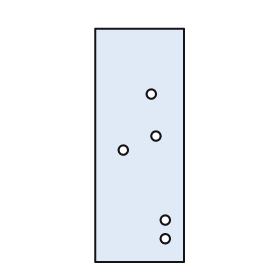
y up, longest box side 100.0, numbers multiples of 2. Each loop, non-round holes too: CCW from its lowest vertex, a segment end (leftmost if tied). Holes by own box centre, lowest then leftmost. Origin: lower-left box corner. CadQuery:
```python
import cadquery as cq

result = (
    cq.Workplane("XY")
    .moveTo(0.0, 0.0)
    .lineTo(38.0, 0.0)
    .lineTo(38.0, 100.0)
    .lineTo(0.0, 100.0)
    .close()
    .moveTo(30.0, 10.0)
    .circle(2.0)
    .moveTo(30.0, 18.0)
    .circle(2.0)
    .moveTo(12.0, 48.0)
    .circle(2.0)
    .moveTo(26.0, 54.0)
    .circle(2.0)
    .moveTo(24.0, 72.0)
    .circle(2.0)
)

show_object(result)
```